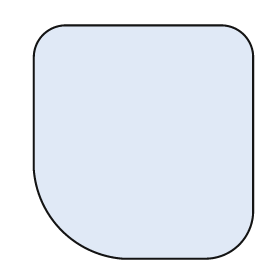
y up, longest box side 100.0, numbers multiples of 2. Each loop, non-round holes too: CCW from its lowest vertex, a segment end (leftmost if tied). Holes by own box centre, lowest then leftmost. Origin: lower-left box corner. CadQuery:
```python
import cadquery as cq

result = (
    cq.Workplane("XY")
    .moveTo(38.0, 0.0)
    .lineTo(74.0, 0.0)
    .threePointArc((88.0, 6.0), (94.0, 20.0))
    .lineTo(94.0, 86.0)
    .threePointArc((90.0, 96.0), (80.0, 100.0))
    .lineTo(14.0, 100.0)
    .threePointArc((4.0, 96.0), (0.0, 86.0))
    .lineTo(0.0, 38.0)
    .threePointArc((12.0, 12.0), (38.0, 0.0))
    .close()
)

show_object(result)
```